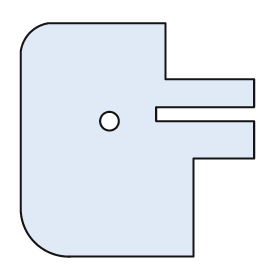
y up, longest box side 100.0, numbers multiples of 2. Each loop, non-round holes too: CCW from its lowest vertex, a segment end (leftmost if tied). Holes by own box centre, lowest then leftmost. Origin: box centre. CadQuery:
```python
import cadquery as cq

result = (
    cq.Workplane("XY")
    .moveTo(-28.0, -50.0)
    .lineTo(24.0, -50.0)
    .lineTo(24.0, -8.0)
    .lineTo(50.0, -8.0)
    .lineTo(50.0, 8.0)
    .lineTo(8.0, 8.0)
    .lineTo(8.0, 14.0)
    .lineTo(50.0, 14.0)
    .lineTo(50.0, 26.0)
    .lineTo(12.0, 26.0)
    .lineTo(12.0, 50.0)
    .lineTo(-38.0, 50.0)
    .threePointArc((-46.0, 46.0), (-50.0, 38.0))
    .lineTo(-50.0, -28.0)
    .threePointArc((-44.0, -44.0), (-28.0, -50.0))
    .close()
    .moveTo(-12.0, 8.0)
    .circle(4.0)
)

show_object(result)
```